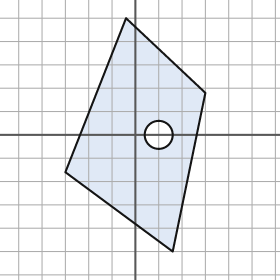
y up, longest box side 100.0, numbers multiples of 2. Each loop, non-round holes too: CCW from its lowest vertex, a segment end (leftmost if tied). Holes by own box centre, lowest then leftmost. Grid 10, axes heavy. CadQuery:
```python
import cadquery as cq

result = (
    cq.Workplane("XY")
    .moveTo(16.0, -50.0)
    .lineTo(30.0, 18.0)
    .lineTo(-4.0, 50.0)
    .lineTo(-30.0, -16.0)
    .close()
    .moveTo(10.0, 0.0)
    .circle(6.0)
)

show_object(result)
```